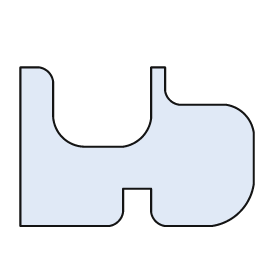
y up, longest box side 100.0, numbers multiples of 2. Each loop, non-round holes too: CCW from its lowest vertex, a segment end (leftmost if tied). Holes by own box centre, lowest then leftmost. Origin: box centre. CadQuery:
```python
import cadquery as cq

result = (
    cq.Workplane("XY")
    .moveTo(-50.0, -34.0)
    .lineTo(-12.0, -34.0)
    .threePointArc((-8.0, -32.0), (-6.0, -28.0))
    .lineTo(-6.0, -18.0)
    .lineTo(6.0, -18.0)
    .lineTo(6.0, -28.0)
    .threePointArc((8.0, -32.0), (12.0, -34.0))
    .lineTo(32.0, -34.0)
    .threePointArc((44.0, -28.0), (50.0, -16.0))
    .lineTo(50.0, 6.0)
    .threePointArc((46.0, 14.0), (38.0, 18.0))
    .lineTo(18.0, 18.0)
    .threePointArc((14.0, 20.0), (12.0, 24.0))
    .lineTo(12.0, 34.0)
    .lineTo(6.0, 34.0)
    .lineTo(6.0, 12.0)
    .threePointArc((2.0, 4.0), (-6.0, 0.0))
    .lineTo(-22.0, 0.0)
    .threePointArc((-32.0, 4.0), (-36.0, 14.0))
    .lineTo(-36.0, 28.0)
    .threePointArc((-38.0, 32.0), (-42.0, 34.0))
    .lineTo(-50.0, 34.0)
    .close()
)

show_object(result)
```